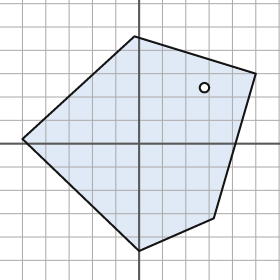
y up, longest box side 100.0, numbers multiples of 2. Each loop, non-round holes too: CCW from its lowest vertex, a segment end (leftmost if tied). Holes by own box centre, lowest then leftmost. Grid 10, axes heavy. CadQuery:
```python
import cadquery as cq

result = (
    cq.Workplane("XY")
    .moveTo(0.0, -46.0)
    .lineTo(32.0, -32.0)
    .lineTo(50.0, 30.0)
    .lineTo(-2.0, 46.0)
    .lineTo(-50.0, 2.0)
    .close()
    .moveTo(28.0, 24.0)
    .circle(2.0)
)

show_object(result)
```